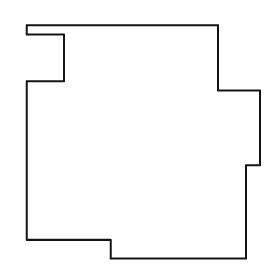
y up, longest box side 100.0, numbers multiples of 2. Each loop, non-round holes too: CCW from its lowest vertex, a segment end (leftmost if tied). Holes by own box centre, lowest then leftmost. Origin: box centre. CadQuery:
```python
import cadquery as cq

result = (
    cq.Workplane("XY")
    .moveTo(-14.0, -50.0)
    .lineTo(44.0, -50.0)
    .lineTo(44.0, -10.0)
    .lineTo(50.0, -10.0)
    .lineTo(50.0, 22.0)
    .lineTo(32.0, 22.0)
    .lineTo(32.0, 50.0)
    .lineTo(-50.0, 50.0)
    .lineTo(-50.0, 46.0)
    .lineTo(-34.0, 46.0)
    .lineTo(-34.0, 26.0)
    .lineTo(-50.0, 26.0)
    .lineTo(-50.0, -42.0)
    .lineTo(-14.0, -42.0)
    .close()
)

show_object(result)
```